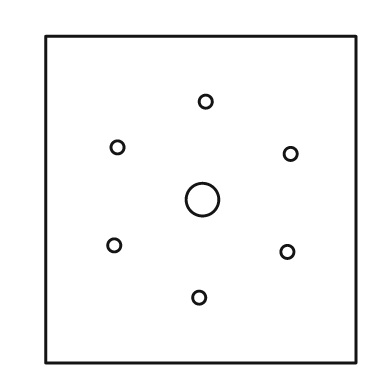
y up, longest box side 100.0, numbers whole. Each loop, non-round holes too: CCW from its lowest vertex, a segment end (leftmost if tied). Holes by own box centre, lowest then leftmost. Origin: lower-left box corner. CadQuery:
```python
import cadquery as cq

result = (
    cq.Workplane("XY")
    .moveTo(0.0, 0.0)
    .lineTo(95.0, 0.0)
    .lineTo(95.0, 100.0)
    .lineTo(0.0, 100.0)
    .close()
    .moveTo(47.0, 20.0)
    .circle(2.0)
    .moveTo(74.0, 34.0)
    .circle(2.0)
    .moveTo(21.0, 36.0)
    .circle(2.0)
    .moveTo(48.0, 50.0)
    .circle(5.0)
    .moveTo(75.0, 64.0)
    .circle(2.0)
    .moveTo(22.0, 66.0)
    .circle(2.0)
    .moveTo(49.0, 80.0)
    .circle(2.0)
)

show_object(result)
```